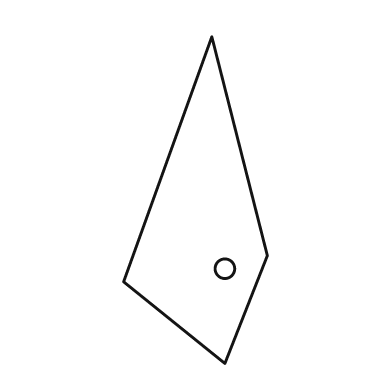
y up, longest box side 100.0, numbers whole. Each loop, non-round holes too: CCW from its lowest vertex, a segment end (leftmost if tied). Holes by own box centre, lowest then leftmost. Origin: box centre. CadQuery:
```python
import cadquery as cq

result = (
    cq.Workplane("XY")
    .moveTo(9.0, -50.0)
    .lineTo(22.0, -17.0)
    .lineTo(5.0, 50.0)
    .lineTo(-22.0, -25.0)
    .close()
    .moveTo(9.0, -21.0)
    .circle(3.0)
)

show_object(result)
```